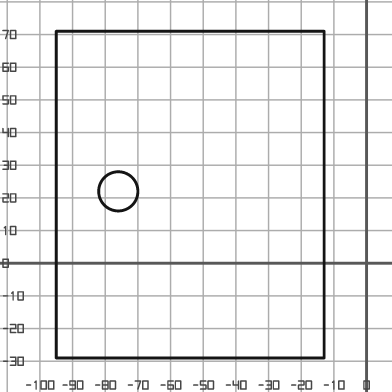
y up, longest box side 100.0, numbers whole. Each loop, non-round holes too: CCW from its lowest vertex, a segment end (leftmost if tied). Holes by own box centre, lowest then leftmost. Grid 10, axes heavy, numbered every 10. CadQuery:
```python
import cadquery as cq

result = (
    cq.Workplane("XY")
    .moveTo(-95.0, -29.0)
    .lineTo(-13.0, -29.0)
    .lineTo(-13.0, 71.0)
    .lineTo(-95.0, 71.0)
    .close()
    .moveTo(-76.0, 22.0)
    .circle(6.0)
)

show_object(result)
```